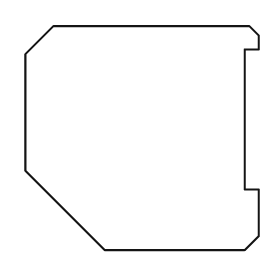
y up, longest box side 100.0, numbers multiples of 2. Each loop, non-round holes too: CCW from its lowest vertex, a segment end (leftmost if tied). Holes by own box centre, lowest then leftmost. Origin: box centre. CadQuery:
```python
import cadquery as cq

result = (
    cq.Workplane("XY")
    .moveTo(-16.0, -48.0)
    .lineTo(44.0, -48.0)
    .lineTo(50.0, -42.0)
    .lineTo(50.0, -22.0)
    .lineTo(44.0, -22.0)
    .lineTo(44.0, 38.0)
    .lineTo(50.0, 38.0)
    .lineTo(50.0, 44.0)
    .lineTo(46.0, 48.0)
    .lineTo(-38.0, 48.0)
    .lineTo(-50.0, 36.0)
    .lineTo(-50.0, -14.0)
    .close()
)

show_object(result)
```